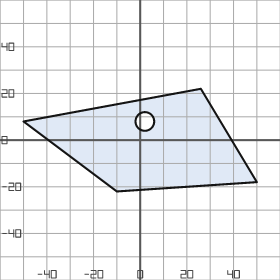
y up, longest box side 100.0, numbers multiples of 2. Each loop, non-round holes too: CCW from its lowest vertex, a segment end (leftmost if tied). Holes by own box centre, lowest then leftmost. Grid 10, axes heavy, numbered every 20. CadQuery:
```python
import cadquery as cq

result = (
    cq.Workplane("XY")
    .moveTo(-10.0, -22.0)
    .lineTo(50.0, -18.0)
    .lineTo(26.0, 22.0)
    .lineTo(-50.0, 8.0)
    .close()
    .moveTo(2.0, 8.0)
    .circle(4.0)
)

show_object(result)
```